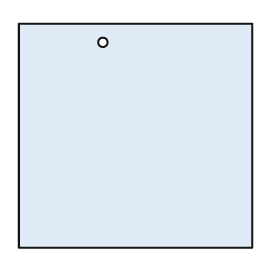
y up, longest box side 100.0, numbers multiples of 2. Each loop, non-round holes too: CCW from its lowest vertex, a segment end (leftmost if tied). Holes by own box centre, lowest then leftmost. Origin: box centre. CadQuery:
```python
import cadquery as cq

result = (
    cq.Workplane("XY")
    .moveTo(-50.0, -48.0)
    .lineTo(50.0, -48.0)
    .lineTo(50.0, 48.0)
    .lineTo(-50.0, 48.0)
    .close()
    .moveTo(-14.0, 40.0)
    .circle(2.0)
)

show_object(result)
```